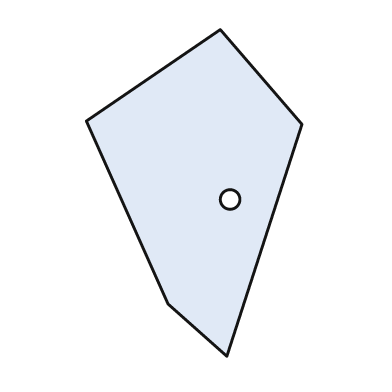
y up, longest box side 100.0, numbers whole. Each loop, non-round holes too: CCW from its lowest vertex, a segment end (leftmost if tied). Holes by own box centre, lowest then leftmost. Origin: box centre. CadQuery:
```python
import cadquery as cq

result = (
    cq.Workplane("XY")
    .moveTo(10.0, -50.0)
    .lineTo(33.0, 21.0)
    .lineTo(8.0, 50.0)
    .lineTo(-33.0, 22.0)
    .lineTo(-8.0, -34.0)
    .close()
    .moveTo(11.0, -2.0)
    .circle(3.0)
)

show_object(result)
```